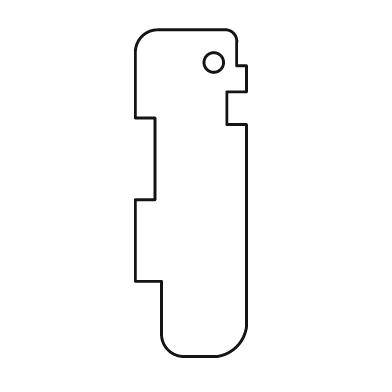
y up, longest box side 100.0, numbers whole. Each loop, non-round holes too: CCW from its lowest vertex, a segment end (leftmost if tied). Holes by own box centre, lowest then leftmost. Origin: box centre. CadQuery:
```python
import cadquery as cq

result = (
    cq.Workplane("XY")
    .moveTo(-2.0, -50.0)
    .lineTo(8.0, -50.0)
    .threePointArc((14.0, -47.0), (17.0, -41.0))
    .lineTo(17.0, 21.0)
    .lineTo(11.0, 21.0)
    .lineTo(11.0, 31.0)
    .lineTo(17.0, 31.0)
    .lineTo(17.0, 39.0)
    .lineTo(14.0, 39.0)
    .lineTo(14.0, 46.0)
    .threePointArc((13.0, 49.0), (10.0, 50.0))
    .lineTo(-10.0, 50.0)
    .threePointArc((-15.0, 48.0), (-17.0, 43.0))
    .lineTo(-17.0, 23.0)
    .lineTo(-11.0, 23.0)
    .lineTo(-11.0, -2.0)
    .lineTo(-17.0, -2.0)
    .lineTo(-17.0, -27.0)
    .lineTo(-9.0, -27.0)
    .lineTo(-9.0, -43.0)
    .threePointArc((-7.0, -48.0), (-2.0, -50.0))
    .close()
    .moveTo(7.0, 40.0)
    .circle(3.0)
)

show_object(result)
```